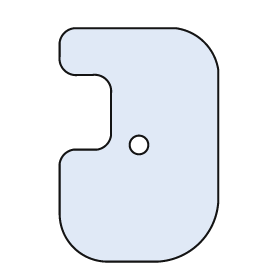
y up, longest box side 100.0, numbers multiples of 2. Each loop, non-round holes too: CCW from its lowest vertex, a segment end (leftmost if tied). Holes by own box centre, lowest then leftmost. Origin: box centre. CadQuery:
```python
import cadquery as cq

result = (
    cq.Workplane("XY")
    .moveTo(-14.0, -50.0)
    .lineTo(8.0, -50.0)
    .threePointArc((26.0, -42.0), (34.0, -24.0))
    .lineTo(34.0, 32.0)
    .threePointArc((28.0, 44.0), (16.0, 50.0))
    .lineTo(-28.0, 50.0)
    .threePointArc((-32.0, 48.0), (-34.0, 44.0))
    .lineTo(-34.0, 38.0)
    .threePointArc((-32.0, 32.0), (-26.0, 30.0))
    .lineTo(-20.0, 30.0)
    .threePointArc((-14.0, 28.0), (-12.0, 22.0))
    .lineTo(-12.0, 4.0)
    .threePointArc((-14.0, 0.0), (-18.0, -2.0))
    .lineTo(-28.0, -2.0)
    .threePointArc((-32.0, -4.0), (-34.0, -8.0))
    .lineTo(-34.0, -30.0)
    .threePointArc((-28.0, -44.0), (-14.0, -50.0))
    .close()
    .moveTo(0.0, 0.0)
    .circle(4.0)
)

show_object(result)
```